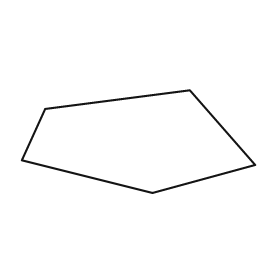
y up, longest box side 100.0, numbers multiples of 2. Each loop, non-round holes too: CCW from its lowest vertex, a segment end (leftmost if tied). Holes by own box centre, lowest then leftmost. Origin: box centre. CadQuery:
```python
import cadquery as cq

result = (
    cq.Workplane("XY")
    .moveTo(6.0, -22.0)
    .lineTo(50.0, -10.0)
    .lineTo(22.0, 22.0)
    .lineTo(-40.0, 14.0)
    .lineTo(-50.0, -8.0)
    .close()
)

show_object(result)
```